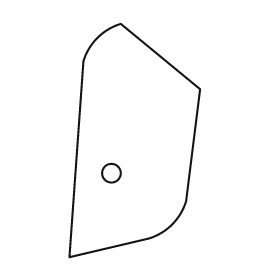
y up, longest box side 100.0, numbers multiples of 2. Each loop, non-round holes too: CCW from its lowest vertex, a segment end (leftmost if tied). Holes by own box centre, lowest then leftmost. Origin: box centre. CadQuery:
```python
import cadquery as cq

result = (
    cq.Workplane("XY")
    .moveTo(-28.0, -50.0)
    .lineTo(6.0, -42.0)
    .threePointArc((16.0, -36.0), (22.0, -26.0))
    .lineTo(28.0, 22.0)
    .lineTo(-6.0, 50.0)
    .threePointArc((-16.0, 44.0), (-22.0, 34.0))
    .close()
    .moveTo(-10.0, -14.0)
    .circle(4.0)
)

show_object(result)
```